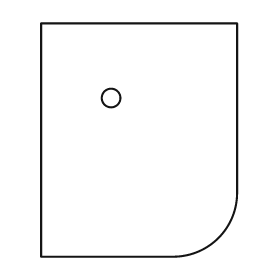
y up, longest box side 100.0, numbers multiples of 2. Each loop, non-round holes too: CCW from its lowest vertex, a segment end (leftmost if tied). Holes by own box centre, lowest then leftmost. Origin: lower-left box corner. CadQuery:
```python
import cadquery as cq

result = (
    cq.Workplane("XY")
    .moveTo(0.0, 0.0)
    .lineTo(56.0, 0.0)
    .threePointArc((76.0, 8.0), (84.0, 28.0))
    .lineTo(84.0, 100.0)
    .lineTo(0.0, 100.0)
    .close()
    .moveTo(30.0, 68.0)
    .circle(4.0)
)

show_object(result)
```